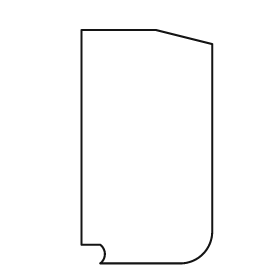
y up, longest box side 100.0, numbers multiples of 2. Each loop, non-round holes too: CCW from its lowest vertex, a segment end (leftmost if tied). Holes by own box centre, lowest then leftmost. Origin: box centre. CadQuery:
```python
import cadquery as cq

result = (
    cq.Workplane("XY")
    .moveTo(-20.0, -50.0)
    .lineTo(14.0, -50.0)
    .threePointArc((24.0, -46.0), (28.0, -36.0))
    .lineTo(28.0, 44.0)
    .lineTo(4.0, 50.0)
    .lineTo(-28.0, 50.0)
    .lineTo(-28.0, -42.0)
    .lineTo(-20.0, -42.0)
    .threePointArc((-18.0, -46.0), (-20.0, -50.0))
    .close()
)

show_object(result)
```